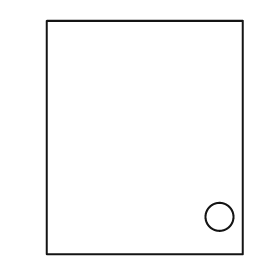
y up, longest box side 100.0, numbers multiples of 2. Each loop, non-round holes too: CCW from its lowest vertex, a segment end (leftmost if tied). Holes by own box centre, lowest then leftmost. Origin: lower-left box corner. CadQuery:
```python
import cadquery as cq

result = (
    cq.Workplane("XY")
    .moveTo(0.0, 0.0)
    .lineTo(84.0, 0.0)
    .lineTo(84.0, 100.0)
    .lineTo(0.0, 100.0)
    .close()
    .moveTo(74.0, 16.0)
    .circle(6.0)
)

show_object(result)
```